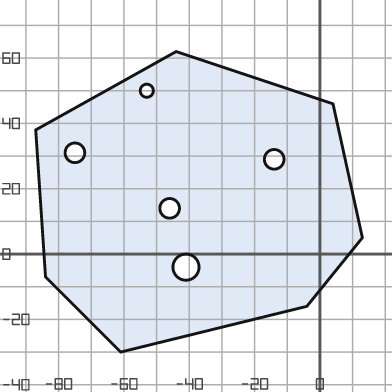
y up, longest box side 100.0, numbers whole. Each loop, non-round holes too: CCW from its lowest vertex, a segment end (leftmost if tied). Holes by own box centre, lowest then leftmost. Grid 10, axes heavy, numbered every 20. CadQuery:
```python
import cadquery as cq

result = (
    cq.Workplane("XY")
    .moveTo(-61.0, -30.0)
    .lineTo(-4.0, -16.0)
    .lineTo(13.0, 5.0)
    .lineTo(4.0, 46.0)
    .lineTo(-44.0, 62.0)
    .lineTo(-87.0, 38.0)
    .lineTo(-84.0, -7.0)
    .close()
    .moveTo(-41.0, -4.0)
    .circle(4.0)
    .moveTo(-46.0, 14.0)
    .circle(3.0)
    .moveTo(-14.0, 29.0)
    .circle(3.0)
    .moveTo(-75.0, 31.0)
    .circle(3.0)
    .moveTo(-53.0, 50.0)
    .circle(2.0)
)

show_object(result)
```